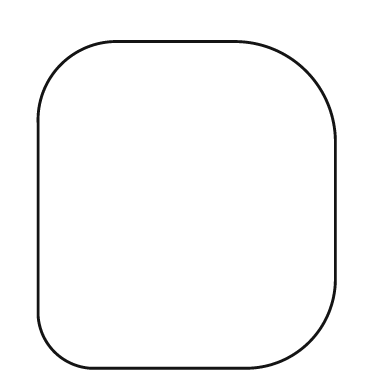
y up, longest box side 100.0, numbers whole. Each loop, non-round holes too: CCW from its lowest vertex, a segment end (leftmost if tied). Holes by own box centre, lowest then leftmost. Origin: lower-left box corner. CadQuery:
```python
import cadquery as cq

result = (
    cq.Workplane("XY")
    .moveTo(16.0, 0.0)
    .lineTo(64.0, 0.0)
    .threePointArc((83.0, 8.0), (91.0, 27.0))
    .lineTo(91.0, 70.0)
    .threePointArc((82.0, 91.0), (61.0, 100.0))
    .lineTo(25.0, 100.0)
    .threePointArc((7.0, 93.0), (0.0, 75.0))
    .lineTo(0.0, 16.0)
    .threePointArc((5.0, 5.0), (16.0, 0.0))
    .close()
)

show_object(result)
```